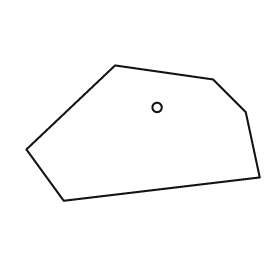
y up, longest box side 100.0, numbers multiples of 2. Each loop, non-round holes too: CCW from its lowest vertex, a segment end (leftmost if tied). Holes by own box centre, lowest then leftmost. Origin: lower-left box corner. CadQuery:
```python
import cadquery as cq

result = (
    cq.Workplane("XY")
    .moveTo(16.0, 0.0)
    .lineTo(100.0, 10.0)
    .lineTo(94.0, 38.0)
    .lineTo(80.0, 52.0)
    .lineTo(38.0, 58.0)
    .lineTo(0.0, 22.0)
    .close()
    .moveTo(56.0, 40.0)
    .circle(2.0)
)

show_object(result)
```